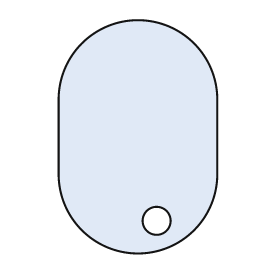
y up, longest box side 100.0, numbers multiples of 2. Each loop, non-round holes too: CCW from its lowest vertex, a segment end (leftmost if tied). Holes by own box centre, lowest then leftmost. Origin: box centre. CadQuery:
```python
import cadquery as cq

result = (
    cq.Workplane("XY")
    .moveTo(-34.0, -16.0)
    .threePointArc((0.0, -50.0), (34.0, -16.0))
    .lineTo(34.0, 16.0)
    .threePointArc((0.0, 50.0), (-34.0, 16.0))
    .close()
    .moveTo(8.0, -36.0)
    .circle(6.0)
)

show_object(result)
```